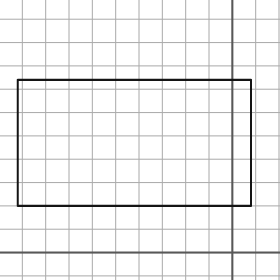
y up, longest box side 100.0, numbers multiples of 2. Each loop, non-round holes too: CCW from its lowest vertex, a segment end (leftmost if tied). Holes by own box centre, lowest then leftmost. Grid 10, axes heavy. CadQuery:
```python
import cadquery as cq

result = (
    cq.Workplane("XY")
    .moveTo(-92.0, 20.0)
    .lineTo(8.0, 20.0)
    .lineTo(8.0, 74.0)
    .lineTo(-92.0, 74.0)
    .close()
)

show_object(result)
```